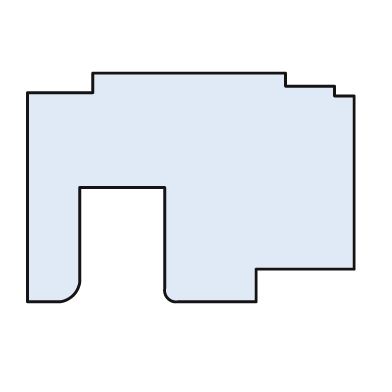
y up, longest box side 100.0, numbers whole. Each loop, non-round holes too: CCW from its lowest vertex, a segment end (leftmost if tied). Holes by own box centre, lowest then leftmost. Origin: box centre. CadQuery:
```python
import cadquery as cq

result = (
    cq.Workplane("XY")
    .moveTo(-50.0, -35.0)
    .lineTo(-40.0, -35.0)
    .threePointArc((-36.0, -33.0), (-34.0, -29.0))
    .lineTo(-34.0, 0.0)
    .lineTo(-8.0, 0.0)
    .lineTo(-8.0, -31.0)
    .threePointArc((-7.0, -34.0), (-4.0, -35.0))
    .lineTo(20.0, -35.0)
    .lineTo(20.0, -25.0)
    .lineTo(50.0, -25.0)
    .lineTo(50.0, 28.0)
    .lineTo(44.0, 28.0)
    .lineTo(44.0, 31.0)
    .lineTo(29.0, 31.0)
    .lineTo(29.0, 35.0)
    .lineTo(-30.0, 35.0)
    .lineTo(-30.0, 29.0)
    .lineTo(-50.0, 29.0)
    .close()
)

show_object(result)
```